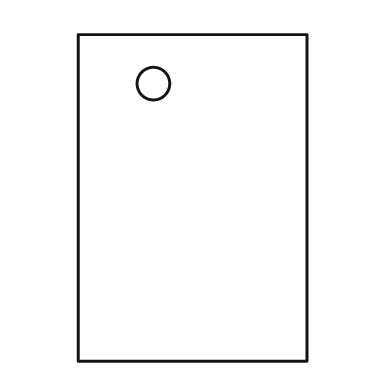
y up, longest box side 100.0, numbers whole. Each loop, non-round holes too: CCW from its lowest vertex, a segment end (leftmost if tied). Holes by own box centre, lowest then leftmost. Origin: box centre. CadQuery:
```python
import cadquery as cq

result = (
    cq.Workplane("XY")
    .moveTo(-35.0, -50.0)
    .lineTo(35.0, -50.0)
    .lineTo(35.0, 50.0)
    .lineTo(-35.0, 50.0)
    .close()
    .moveTo(-12.0, 35.0)
    .circle(5.0)
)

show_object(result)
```